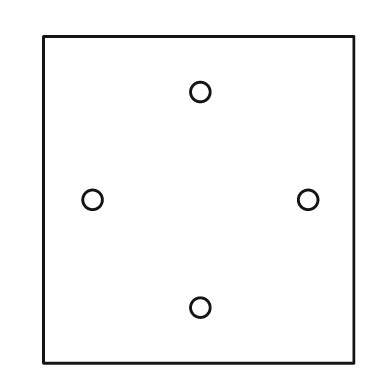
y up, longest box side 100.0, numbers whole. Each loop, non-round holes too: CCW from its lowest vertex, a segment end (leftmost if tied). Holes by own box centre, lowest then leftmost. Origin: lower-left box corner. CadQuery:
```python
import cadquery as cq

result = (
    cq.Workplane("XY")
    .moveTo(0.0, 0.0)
    .lineTo(95.0, 0.0)
    .lineTo(95.0, 100.0)
    .lineTo(0.0, 100.0)
    .close()
    .moveTo(48.0, 17.0)
    .circle(3.0)
    .moveTo(15.0, 50.0)
    .circle(3.0)
    .moveTo(81.0, 50.0)
    .circle(3.0)
    .moveTo(48.0, 83.0)
    .circle(3.0)
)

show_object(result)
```